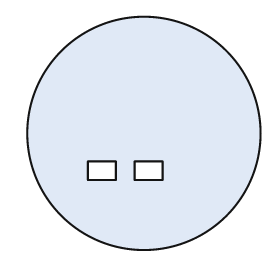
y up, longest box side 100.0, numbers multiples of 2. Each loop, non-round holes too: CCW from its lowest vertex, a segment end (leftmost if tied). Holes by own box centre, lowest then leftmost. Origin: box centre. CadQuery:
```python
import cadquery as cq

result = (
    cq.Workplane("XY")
    .moveTo(0.0, 0.0)
    .circle(50.0)
    .moveTo(-24.0, -20.0)
    .lineTo(-12.0, -20.0)
    .lineTo(-12.0, -12.0)
    .lineTo(-24.0, -12.0)
    .close()
    .moveTo(-4.0, -20.0)
    .lineTo(8.0, -20.0)
    .lineTo(8.0, -12.0)
    .lineTo(-4.0, -12.0)
    .close()
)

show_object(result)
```